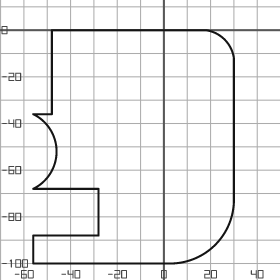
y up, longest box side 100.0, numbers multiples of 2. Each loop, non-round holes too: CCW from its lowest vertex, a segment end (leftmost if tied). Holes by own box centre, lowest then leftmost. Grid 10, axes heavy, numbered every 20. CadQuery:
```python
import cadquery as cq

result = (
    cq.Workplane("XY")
    .moveTo(-56.0, -100.0)
    .lineTo(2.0, -100.0)
    .threePointArc((22.0, -92.0), (30.0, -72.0))
    .lineTo(30.0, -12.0)
    .threePointArc((26.0, -4.0), (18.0, 0.0))
    .lineTo(-48.0, 0.0)
    .lineTo(-48.0, -36.0)
    .lineTo(-56.0, -36.0)
    .threePointArc((-46.0, -52.0), (-56.0, -68.0))
    .lineTo(-28.0, -68.0)
    .lineTo(-28.0, -88.0)
    .lineTo(-56.0, -88.0)
    .close()
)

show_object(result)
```